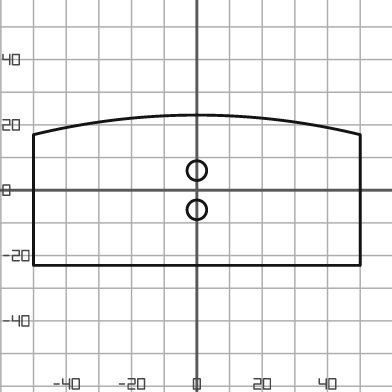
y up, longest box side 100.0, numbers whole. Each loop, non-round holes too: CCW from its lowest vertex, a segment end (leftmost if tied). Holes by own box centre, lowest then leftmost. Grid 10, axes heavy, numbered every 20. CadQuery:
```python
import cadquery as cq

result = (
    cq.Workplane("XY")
    .moveTo(-50.0, -23.0)
    .lineTo(50.0, -23.0)
    .lineTo(50.0, 17.0)
    .threePointArc((0.0, 23.0), (-50.0, 17.0))
    .close()
    .moveTo(0.0, -6.0)
    .circle(3.0)
    .moveTo(0.0, 6.0)
    .circle(3.0)
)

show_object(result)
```